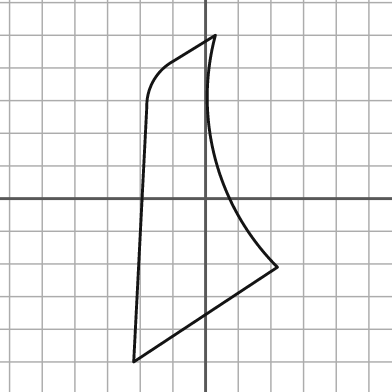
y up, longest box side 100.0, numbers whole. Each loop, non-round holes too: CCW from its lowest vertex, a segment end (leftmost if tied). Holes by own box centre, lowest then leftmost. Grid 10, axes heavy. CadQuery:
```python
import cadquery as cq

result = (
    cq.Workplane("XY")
    .moveTo(-22.0, -50.0)
    .lineTo(22.0, -21.0)
    .threePointArc((3.0, 12.0), (3.0, 50.0))
    .lineTo(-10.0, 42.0)
    .threePointArc((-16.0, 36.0), (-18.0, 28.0))
    .close()
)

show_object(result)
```